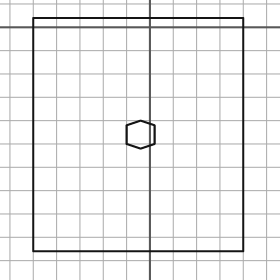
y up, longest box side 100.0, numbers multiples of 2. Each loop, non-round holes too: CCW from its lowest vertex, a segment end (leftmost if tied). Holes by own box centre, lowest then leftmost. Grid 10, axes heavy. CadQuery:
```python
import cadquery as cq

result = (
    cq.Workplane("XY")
    .moveTo(-50.0, -96.0)
    .lineTo(40.0, -96.0)
    .lineTo(40.0, 4.0)
    .lineTo(-50.0, 4.0)
    .close()
    .moveTo(-4.0, -52.0)
    .lineTo(2.0, -50.0)
    .lineTo(2.0, -42.0)
    .lineTo(-4.0, -40.0)
    .lineTo(-10.0, -42.0)
    .lineTo(-10.0, -50.0)
    .close()
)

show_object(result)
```